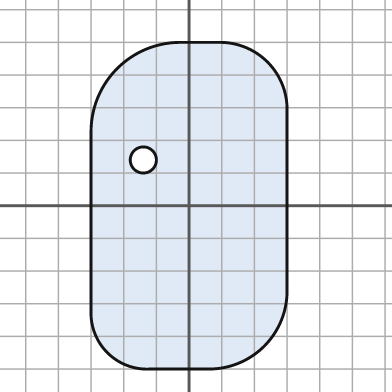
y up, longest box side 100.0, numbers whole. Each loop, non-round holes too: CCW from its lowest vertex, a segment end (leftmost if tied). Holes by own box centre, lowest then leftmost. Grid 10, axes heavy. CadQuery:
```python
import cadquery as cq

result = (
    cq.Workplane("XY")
    .moveTo(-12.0, -50.0)
    .lineTo(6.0, -50.0)
    .threePointArc((23.0, -43.0), (30.0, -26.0))
    .lineTo(30.0, 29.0)
    .threePointArc((24.0, 44.0), (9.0, 50.0))
    .lineTo(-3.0, 50.0)
    .threePointArc((-22.0, 42.0), (-30.0, 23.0))
    .lineTo(-30.0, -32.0)
    .threePointArc((-25.0, -45.0), (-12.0, -50.0))
    .close()
    .moveTo(-14.0, 14.0)
    .circle(4.0)
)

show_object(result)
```